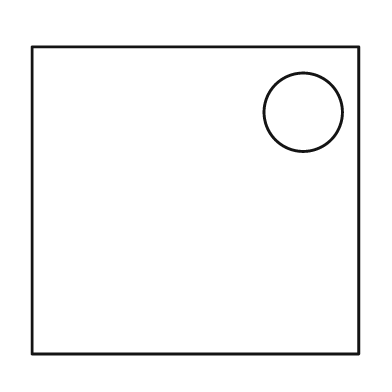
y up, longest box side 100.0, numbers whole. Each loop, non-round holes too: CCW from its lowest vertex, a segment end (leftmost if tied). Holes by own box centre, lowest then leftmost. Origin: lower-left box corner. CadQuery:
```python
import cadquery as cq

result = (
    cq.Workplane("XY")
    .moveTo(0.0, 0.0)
    .lineTo(100.0, 0.0)
    .lineTo(100.0, 94.0)
    .lineTo(0.0, 94.0)
    .close()
    .moveTo(83.0, 74.0)
    .circle(12.0)
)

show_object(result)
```